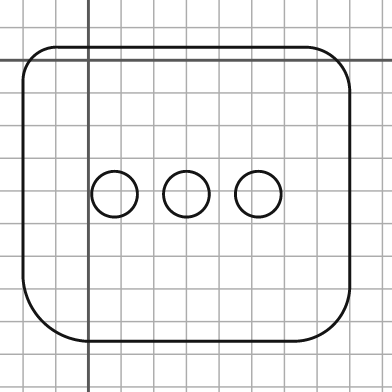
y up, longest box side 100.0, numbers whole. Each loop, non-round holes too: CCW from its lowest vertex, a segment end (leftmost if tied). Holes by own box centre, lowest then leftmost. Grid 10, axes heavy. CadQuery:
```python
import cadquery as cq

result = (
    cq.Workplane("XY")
    .moveTo(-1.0, -86.0)
    .lineTo(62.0, -86.0)
    .threePointArc((75.0, -81.0), (80.0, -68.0))
    .lineTo(80.0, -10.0)
    .threePointArc((76.0, 0.0), (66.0, 4.0))
    .lineTo(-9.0, 4.0)
    .threePointArc((-17.0, 1.0), (-20.0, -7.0))
    .lineTo(-20.0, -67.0)
    .threePointArc((-14.0, -80.0), (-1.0, -86.0))
    .close()
    .moveTo(8.0, -41.0)
    .circle(7.0)
    .moveTo(30.0, -41.0)
    .circle(7.0)
    .moveTo(52.0, -41.0)
    .circle(7.0)
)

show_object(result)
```